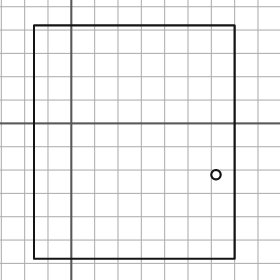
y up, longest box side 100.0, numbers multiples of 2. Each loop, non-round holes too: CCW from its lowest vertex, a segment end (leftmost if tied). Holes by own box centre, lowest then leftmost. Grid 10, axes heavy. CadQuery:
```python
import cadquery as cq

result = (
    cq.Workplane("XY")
    .moveTo(-16.0, -58.0)
    .lineTo(70.0, -58.0)
    .lineTo(70.0, 42.0)
    .lineTo(-16.0, 42.0)
    .close()
    .moveTo(62.0, -22.0)
    .circle(2.0)
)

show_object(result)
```